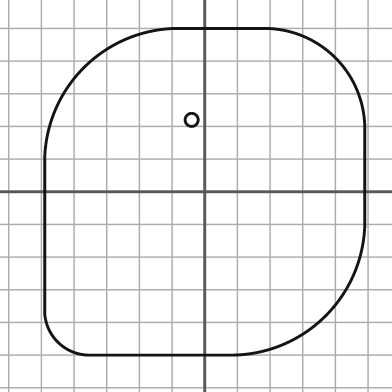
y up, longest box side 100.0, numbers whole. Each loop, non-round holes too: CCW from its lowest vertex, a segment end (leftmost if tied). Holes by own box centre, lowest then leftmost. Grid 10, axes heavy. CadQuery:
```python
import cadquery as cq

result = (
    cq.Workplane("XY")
    .moveTo(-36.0, -50.0)
    .lineTo(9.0, -50.0)
    .threePointArc((37.0, -38.0), (49.0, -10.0))
    .lineTo(49.0, 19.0)
    .threePointArc((40.0, 41.0), (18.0, 50.0))
    .lineTo(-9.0, 50.0)
    .threePointArc((-37.0, 38.0), (-49.0, 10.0))
    .lineTo(-49.0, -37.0)
    .threePointArc((-45.0, -46.0), (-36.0, -50.0))
    .close()
    .moveTo(-4.0, 22.0)
    .circle(2.0)
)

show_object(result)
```